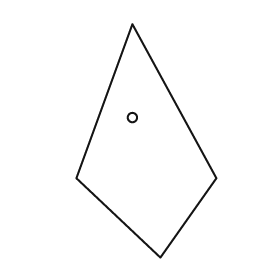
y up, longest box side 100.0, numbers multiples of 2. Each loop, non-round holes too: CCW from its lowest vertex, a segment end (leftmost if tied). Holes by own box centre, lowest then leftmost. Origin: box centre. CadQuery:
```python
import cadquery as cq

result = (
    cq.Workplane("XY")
    .moveTo(6.0, -50.0)
    .lineTo(30.0, -16.0)
    .lineTo(-6.0, 50.0)
    .lineTo(-30.0, -16.0)
    .close()
    .moveTo(-6.0, 10.0)
    .circle(2.0)
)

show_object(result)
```